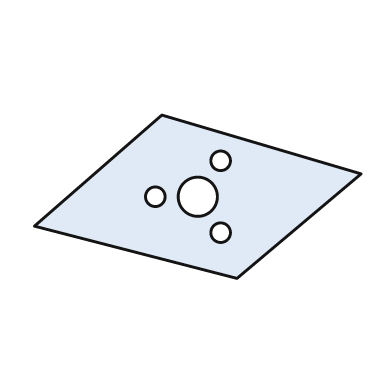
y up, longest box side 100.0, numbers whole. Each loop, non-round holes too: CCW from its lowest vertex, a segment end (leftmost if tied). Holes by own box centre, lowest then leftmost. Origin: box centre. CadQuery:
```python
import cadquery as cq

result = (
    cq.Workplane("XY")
    .moveTo(12.0, -25.0)
    .lineTo(50.0, 7.0)
    .lineTo(-11.0, 25.0)
    .lineTo(-50.0, -9.0)
    .close()
    .moveTo(7.0, -11.0)
    .circle(3.0)
    .moveTo(-13.0, 0.0)
    .circle(3.0)
    .moveTo(0.0, 0.0)
    .circle(6.0)
    .moveTo(7.0, 11.0)
    .circle(3.0)
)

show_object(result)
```